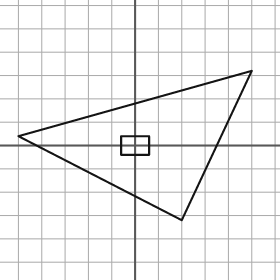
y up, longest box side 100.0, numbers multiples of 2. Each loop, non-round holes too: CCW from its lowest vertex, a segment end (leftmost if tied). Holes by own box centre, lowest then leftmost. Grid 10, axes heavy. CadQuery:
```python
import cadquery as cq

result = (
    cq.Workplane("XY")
    .moveTo(20.0, -32.0)
    .lineTo(50.0, 32.0)
    .lineTo(-50.0, 4.0)
    .close()
    .moveTo(-6.0, -4.0)
    .lineTo(6.0, -4.0)
    .lineTo(6.0, 4.0)
    .lineTo(-6.0, 4.0)
    .close()
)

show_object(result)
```